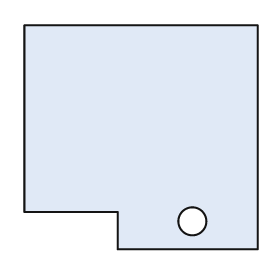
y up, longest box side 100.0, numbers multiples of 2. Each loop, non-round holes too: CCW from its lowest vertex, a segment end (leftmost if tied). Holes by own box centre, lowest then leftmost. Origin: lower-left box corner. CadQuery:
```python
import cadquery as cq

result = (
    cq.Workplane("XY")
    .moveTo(40.0, 0.0)
    .lineTo(100.0, 0.0)
    .lineTo(100.0, 96.0)
    .lineTo(0.0, 96.0)
    .lineTo(0.0, 16.0)
    .lineTo(40.0, 16.0)
    .close()
    .moveTo(72.0, 12.0)
    .circle(6.0)
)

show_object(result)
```